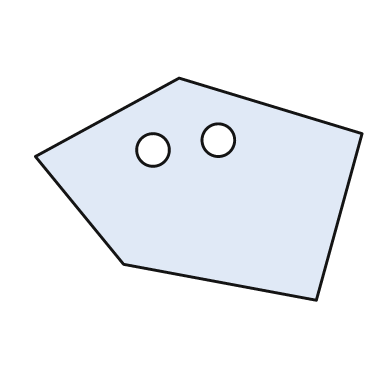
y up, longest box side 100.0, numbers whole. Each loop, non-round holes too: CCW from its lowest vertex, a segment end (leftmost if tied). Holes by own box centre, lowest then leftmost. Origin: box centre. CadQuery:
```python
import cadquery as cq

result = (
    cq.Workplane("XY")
    .moveTo(36.0, -34.0)
    .lineTo(50.0, 17.0)
    .lineTo(-6.0, 34.0)
    .lineTo(-50.0, 10.0)
    .lineTo(-23.0, -23.0)
    .close()
    .moveTo(-14.0, 12.0)
    .circle(5.0)
    .moveTo(6.0, 15.0)
    .circle(5.0)
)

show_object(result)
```